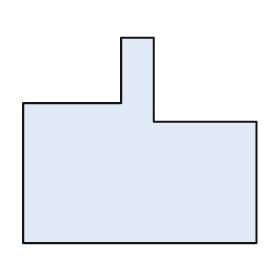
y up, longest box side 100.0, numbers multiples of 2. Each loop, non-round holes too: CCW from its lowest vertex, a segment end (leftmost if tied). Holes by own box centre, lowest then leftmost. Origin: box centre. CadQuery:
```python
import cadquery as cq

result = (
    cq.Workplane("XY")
    .moveTo(-50.0, -44.0)
    .lineTo(50.0, -44.0)
    .lineTo(50.0, 8.0)
    .lineTo(6.0, 8.0)
    .lineTo(6.0, 44.0)
    .lineTo(-8.0, 44.0)
    .lineTo(-8.0, 16.0)
    .lineTo(-50.0, 16.0)
    .close()
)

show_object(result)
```